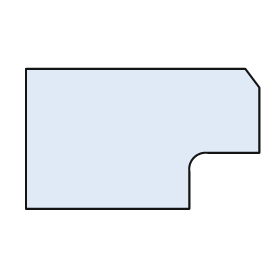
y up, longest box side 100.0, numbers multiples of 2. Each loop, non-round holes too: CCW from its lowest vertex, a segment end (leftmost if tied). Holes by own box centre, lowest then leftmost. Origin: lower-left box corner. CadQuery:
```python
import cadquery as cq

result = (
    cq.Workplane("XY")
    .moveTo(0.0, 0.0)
    .lineTo(70.0, 0.0)
    .lineTo(70.0, 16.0)
    .threePointArc((72.0, 22.0), (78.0, 24.0))
    .lineTo(100.0, 24.0)
    .lineTo(100.0, 52.0)
    .lineTo(94.0, 60.0)
    .lineTo(0.0, 60.0)
    .close()
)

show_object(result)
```